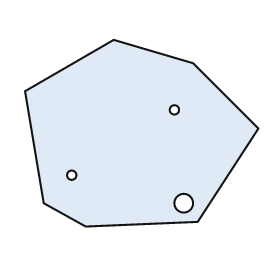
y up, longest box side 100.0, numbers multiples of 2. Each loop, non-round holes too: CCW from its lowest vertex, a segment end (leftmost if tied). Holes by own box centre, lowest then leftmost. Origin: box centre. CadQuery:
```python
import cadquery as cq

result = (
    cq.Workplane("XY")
    .moveTo(-24.0, -40.0)
    .lineTo(24.0, -38.0)
    .lineTo(50.0, 2.0)
    .lineTo(22.0, 30.0)
    .lineTo(-12.0, 40.0)
    .lineTo(-50.0, 18.0)
    .lineTo(-42.0, -30.0)
    .close()
    .moveTo(18.0, -30.0)
    .circle(4.0)
    .moveTo(-30.0, -18.0)
    .circle(2.0)
    .moveTo(14.0, 10.0)
    .circle(2.0)
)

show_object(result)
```